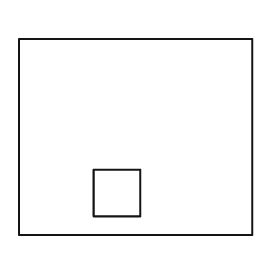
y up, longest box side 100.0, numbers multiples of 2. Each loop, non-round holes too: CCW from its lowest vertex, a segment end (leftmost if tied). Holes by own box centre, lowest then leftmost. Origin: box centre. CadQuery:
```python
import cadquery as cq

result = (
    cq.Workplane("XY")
    .moveTo(-50.0, -42.0)
    .lineTo(50.0, -42.0)
    .lineTo(50.0, 42.0)
    .lineTo(-50.0, 42.0)
    .close()
    .moveTo(-18.0, -34.0)
    .lineTo(2.0, -34.0)
    .lineTo(2.0, -14.0)
    .lineTo(-18.0, -14.0)
    .close()
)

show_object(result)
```